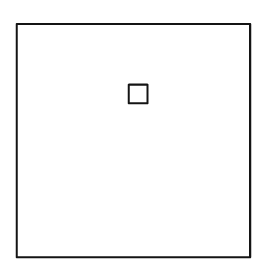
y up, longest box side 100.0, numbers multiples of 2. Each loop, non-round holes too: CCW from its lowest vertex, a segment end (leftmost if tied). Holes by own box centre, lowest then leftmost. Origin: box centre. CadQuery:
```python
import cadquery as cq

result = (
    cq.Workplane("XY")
    .moveTo(-50.0, -50.0)
    .lineTo(50.0, -50.0)
    .lineTo(50.0, 50.0)
    .lineTo(-50.0, 50.0)
    .close()
    .moveTo(-2.0, 16.0)
    .lineTo(6.0, 16.0)
    .lineTo(6.0, 24.0)
    .lineTo(-2.0, 24.0)
    .close()
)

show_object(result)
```